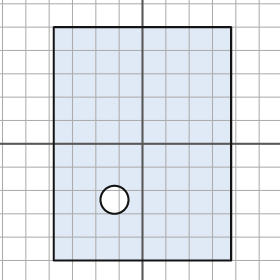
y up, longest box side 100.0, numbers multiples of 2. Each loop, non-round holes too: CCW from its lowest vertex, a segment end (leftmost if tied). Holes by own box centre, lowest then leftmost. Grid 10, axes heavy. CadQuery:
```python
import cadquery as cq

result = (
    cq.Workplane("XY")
    .moveTo(-38.0, -50.0)
    .lineTo(38.0, -50.0)
    .lineTo(38.0, 50.0)
    .lineTo(-38.0, 50.0)
    .close()
    .moveTo(-12.0, -24.0)
    .circle(6.0)
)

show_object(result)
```